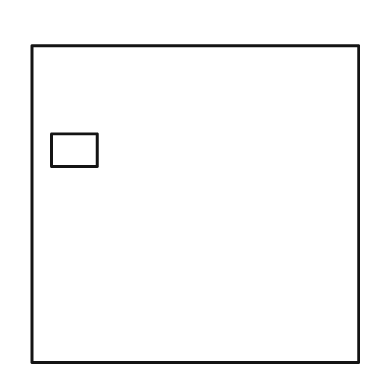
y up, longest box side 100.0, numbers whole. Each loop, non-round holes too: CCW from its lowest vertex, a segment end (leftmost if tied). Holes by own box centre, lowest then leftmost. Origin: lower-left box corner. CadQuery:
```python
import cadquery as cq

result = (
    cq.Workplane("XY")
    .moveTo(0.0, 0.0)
    .lineTo(100.0, 0.0)
    .lineTo(100.0, 97.0)
    .lineTo(0.0, 97.0)
    .close()
    .moveTo(6.0, 60.0)
    .lineTo(20.0, 60.0)
    .lineTo(20.0, 70.0)
    .lineTo(6.0, 70.0)
    .close()
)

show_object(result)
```